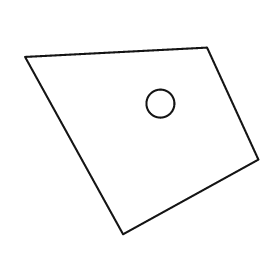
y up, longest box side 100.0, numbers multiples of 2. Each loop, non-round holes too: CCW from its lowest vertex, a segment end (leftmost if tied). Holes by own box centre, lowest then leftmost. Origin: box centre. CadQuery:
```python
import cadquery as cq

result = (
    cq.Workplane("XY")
    .moveTo(-8.0, -40.0)
    .lineTo(50.0, -8.0)
    .lineTo(28.0, 40.0)
    .lineTo(-50.0, 36.0)
    .close()
    .moveTo(8.0, 16.0)
    .circle(6.0)
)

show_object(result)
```